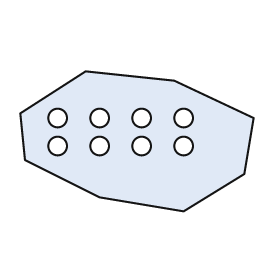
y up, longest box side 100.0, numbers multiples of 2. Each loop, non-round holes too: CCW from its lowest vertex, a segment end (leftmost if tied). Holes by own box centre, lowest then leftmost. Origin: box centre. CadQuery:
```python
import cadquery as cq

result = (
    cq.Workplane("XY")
    .moveTo(20.0, -30.0)
    .lineTo(46.0, -14.0)
    .lineTo(50.0, 10.0)
    .lineTo(16.0, 26.0)
    .lineTo(-22.0, 30.0)
    .lineTo(-50.0, 12.0)
    .lineTo(-48.0, -8.0)
    .lineTo(-16.0, -24.0)
    .close()
    .moveTo(-34.0, -2.0)
    .circle(4.0)
    .moveTo(-16.0, -2.0)
    .circle(4.0)
    .moveTo(2.0, -2.0)
    .circle(4.0)
    .moveTo(20.0, -2.0)
    .circle(4.0)
    .moveTo(-34.0, 10.0)
    .circle(4.0)
    .moveTo(-16.0, 10.0)
    .circle(4.0)
    .moveTo(2.0, 10.0)
    .circle(4.0)
    .moveTo(20.0, 10.0)
    .circle(4.0)
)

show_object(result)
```